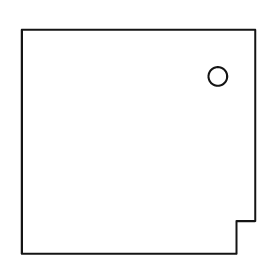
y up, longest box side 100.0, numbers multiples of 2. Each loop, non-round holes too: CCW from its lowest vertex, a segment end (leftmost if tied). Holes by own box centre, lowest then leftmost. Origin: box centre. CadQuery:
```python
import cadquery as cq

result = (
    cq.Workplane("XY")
    .moveTo(-50.0, -48.0)
    .lineTo(42.0, -48.0)
    .lineTo(42.0, -34.0)
    .lineTo(50.0, -34.0)
    .lineTo(50.0, 48.0)
    .lineTo(-50.0, 48.0)
    .close()
    .moveTo(34.0, 28.0)
    .circle(4.0)
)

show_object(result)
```